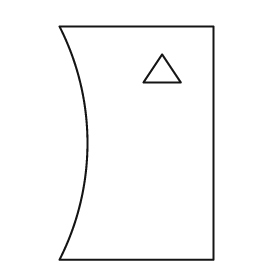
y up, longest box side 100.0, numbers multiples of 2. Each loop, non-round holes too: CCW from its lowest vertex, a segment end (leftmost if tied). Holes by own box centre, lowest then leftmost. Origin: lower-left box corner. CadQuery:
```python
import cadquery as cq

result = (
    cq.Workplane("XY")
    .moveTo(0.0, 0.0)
    .lineTo(66.0, 0.0)
    .lineTo(66.0, 100.0)
    .lineTo(0.0, 100.0)
    .threePointArc((12.0, 50.0), (0.0, 0.0))
    .close()
    .moveTo(36.0, 76.0)
    .lineTo(52.0, 76.0)
    .lineTo(44.0, 88.0)
    .close()
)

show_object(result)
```